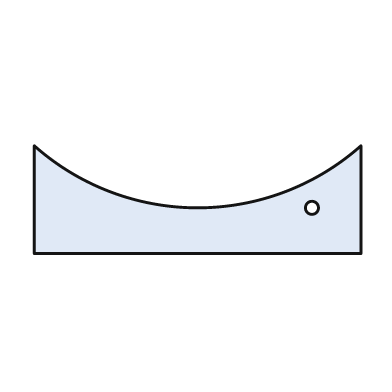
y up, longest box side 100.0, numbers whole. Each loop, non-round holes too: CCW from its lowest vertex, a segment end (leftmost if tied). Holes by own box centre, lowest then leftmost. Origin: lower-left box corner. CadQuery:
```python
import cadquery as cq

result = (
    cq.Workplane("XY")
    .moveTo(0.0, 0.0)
    .lineTo(100.0, 0.0)
    .lineTo(100.0, 33.0)
    .threePointArc((50.0, 14.0), (0.0, 33.0))
    .close()
    .moveTo(85.0, 14.0)
    .circle(2.0)
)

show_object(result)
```